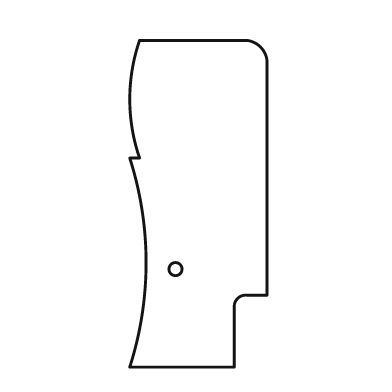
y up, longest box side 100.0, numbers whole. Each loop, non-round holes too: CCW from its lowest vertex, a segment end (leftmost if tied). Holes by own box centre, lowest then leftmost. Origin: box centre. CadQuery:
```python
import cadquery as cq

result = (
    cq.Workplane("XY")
    .moveTo(-21.0, -50.0)
    .lineTo(11.0, -50.0)
    .lineTo(11.0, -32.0)
    .threePointArc((12.0, -29.0), (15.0, -28.0))
    .lineTo(21.0, -28.0)
    .lineTo(21.0, 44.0)
    .threePointArc((19.0, 48.0), (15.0, 50.0))
    .lineTo(-18.0, 50.0)
    .threePointArc((-21.0, 32.0), (-18.0, 14.0))
    .lineTo(-21.0, 14.0)
    .threePointArc((-16.0, -18.0), (-21.0, -50.0))
    .close()
    .moveTo(-7.0, -20.0)
    .circle(2.0)
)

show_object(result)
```